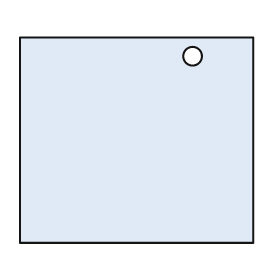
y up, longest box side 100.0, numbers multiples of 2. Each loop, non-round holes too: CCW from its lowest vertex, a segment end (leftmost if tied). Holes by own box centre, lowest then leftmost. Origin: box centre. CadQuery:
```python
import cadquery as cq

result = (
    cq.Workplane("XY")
    .moveTo(-50.0, -44.0)
    .lineTo(50.0, -44.0)
    .lineTo(50.0, 44.0)
    .lineTo(-50.0, 44.0)
    .close()
    .moveTo(24.0, 36.0)
    .circle(4.0)
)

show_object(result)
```